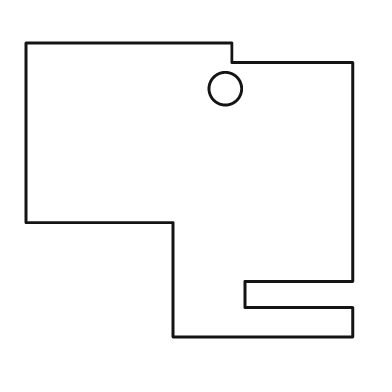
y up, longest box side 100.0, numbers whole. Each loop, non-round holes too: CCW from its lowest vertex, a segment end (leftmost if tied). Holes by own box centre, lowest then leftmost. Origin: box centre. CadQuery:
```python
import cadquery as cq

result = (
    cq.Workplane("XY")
    .moveTo(-5.0, -45.0)
    .lineTo(50.0, -45.0)
    .lineTo(50.0, -36.0)
    .lineTo(17.0, -36.0)
    .lineTo(17.0, -28.0)
    .lineTo(50.0, -28.0)
    .lineTo(50.0, 39.0)
    .lineTo(13.0, 39.0)
    .lineTo(13.0, 45.0)
    .lineTo(-50.0, 45.0)
    .lineTo(-50.0, -10.0)
    .lineTo(-5.0, -10.0)
    .close()
    .moveTo(11.0, 31.0)
    .circle(5.0)
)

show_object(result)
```